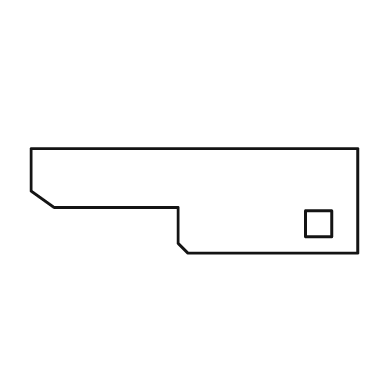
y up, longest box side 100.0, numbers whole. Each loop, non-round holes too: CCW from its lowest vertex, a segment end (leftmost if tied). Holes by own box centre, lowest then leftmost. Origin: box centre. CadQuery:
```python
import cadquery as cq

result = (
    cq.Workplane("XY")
    .moveTo(-2.0, -16.0)
    .lineTo(50.0, -16.0)
    .lineTo(50.0, 16.0)
    .lineTo(-50.0, 16.0)
    .lineTo(-50.0, 3.0)
    .lineTo(-43.0, -2.0)
    .lineTo(-5.0, -2.0)
    .lineTo(-5.0, -13.0)
    .close()
    .moveTo(34.0, -11.0)
    .lineTo(42.0, -11.0)
    .lineTo(42.0, -3.0)
    .lineTo(34.0, -3.0)
    .close()
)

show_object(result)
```